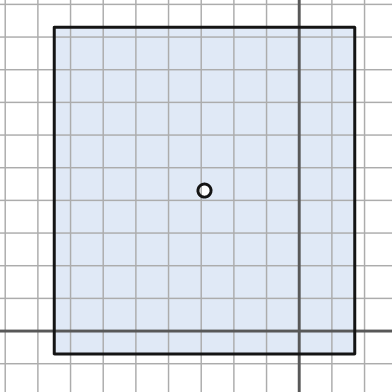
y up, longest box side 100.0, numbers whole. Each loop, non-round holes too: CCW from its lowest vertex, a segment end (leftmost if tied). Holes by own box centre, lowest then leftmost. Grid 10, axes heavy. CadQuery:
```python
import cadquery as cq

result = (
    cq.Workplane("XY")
    .moveTo(-75.0, -7.0)
    .lineTo(17.0, -7.0)
    .lineTo(17.0, 93.0)
    .lineTo(-75.0, 93.0)
    .close()
    .moveTo(-29.0, 43.0)
    .circle(2.0)
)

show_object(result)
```